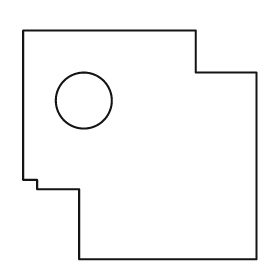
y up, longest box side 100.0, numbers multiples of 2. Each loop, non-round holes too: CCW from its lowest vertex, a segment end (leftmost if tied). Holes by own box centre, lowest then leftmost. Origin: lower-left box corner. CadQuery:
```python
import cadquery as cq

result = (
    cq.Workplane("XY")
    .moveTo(24.0, 0.0)
    .lineTo(100.0, 0.0)
    .lineTo(100.0, 80.0)
    .lineTo(74.0, 80.0)
    .lineTo(74.0, 98.0)
    .lineTo(0.0, 98.0)
    .lineTo(0.0, 34.0)
    .lineTo(6.0, 34.0)
    .lineTo(6.0, 30.0)
    .lineTo(24.0, 30.0)
    .close()
    .moveTo(26.0, 68.0)
    .circle(12.0)
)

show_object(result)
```